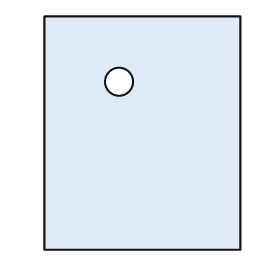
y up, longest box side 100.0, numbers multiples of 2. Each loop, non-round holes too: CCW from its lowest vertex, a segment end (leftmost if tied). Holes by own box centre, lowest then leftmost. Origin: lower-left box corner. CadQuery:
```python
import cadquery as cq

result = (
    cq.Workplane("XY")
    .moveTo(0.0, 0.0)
    .lineTo(84.0, 0.0)
    .lineTo(84.0, 100.0)
    .lineTo(0.0, 100.0)
    .close()
    .moveTo(32.0, 72.0)
    .circle(6.0)
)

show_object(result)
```